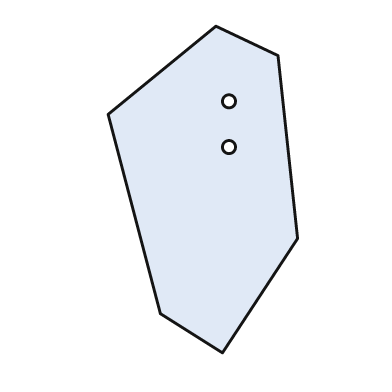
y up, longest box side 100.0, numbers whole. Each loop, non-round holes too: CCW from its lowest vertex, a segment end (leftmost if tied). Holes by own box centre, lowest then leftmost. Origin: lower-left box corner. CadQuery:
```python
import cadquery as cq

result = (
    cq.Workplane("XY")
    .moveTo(35.0, 0.0)
    .lineTo(58.0, 35.0)
    .lineTo(52.0, 91.0)
    .lineTo(33.0, 100.0)
    .lineTo(0.0, 73.0)
    .lineTo(16.0, 12.0)
    .close()
    .moveTo(37.0, 63.0)
    .circle(2.0)
    .moveTo(37.0, 77.0)
    .circle(2.0)
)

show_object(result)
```